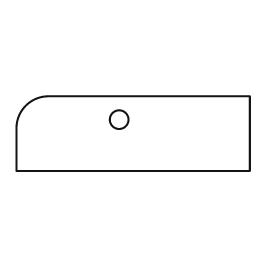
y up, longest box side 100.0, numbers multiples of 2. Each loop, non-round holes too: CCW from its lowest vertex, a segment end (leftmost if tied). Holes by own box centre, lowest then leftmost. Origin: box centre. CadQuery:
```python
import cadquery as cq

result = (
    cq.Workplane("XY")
    .moveTo(-50.0, -16.0)
    .lineTo(50.0, -16.0)
    .lineTo(50.0, 16.0)
    .lineTo(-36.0, 16.0)
    .threePointArc((-46.0, 12.0), (-50.0, 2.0))
    .close()
    .moveTo(-6.0, 6.0)
    .circle(4.0)
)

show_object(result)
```